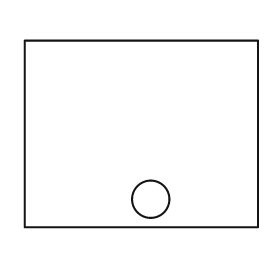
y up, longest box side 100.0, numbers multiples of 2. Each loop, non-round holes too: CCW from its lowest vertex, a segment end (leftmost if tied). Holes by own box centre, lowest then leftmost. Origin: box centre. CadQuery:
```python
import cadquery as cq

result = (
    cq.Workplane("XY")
    .moveTo(-50.0, -40.0)
    .lineTo(50.0, -40.0)
    .lineTo(50.0, 40.0)
    .lineTo(-50.0, 40.0)
    .close()
    .moveTo(4.0, -28.0)
    .circle(8.0)
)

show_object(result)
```